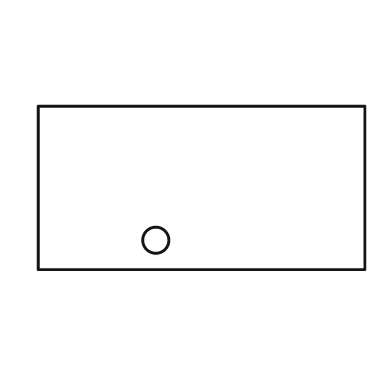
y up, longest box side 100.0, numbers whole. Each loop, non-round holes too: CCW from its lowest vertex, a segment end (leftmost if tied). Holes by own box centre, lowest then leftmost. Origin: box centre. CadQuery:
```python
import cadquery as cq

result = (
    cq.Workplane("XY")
    .moveTo(-50.0, -25.0)
    .lineTo(50.0, -25.0)
    .lineTo(50.0, 25.0)
    .lineTo(-50.0, 25.0)
    .close()
    .moveTo(-14.0, -16.0)
    .circle(4.0)
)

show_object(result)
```